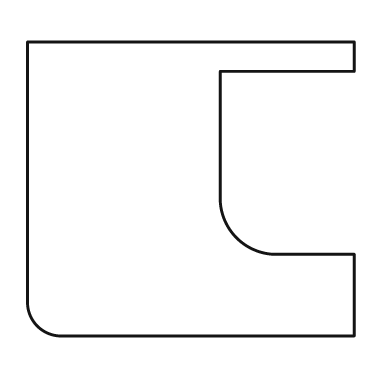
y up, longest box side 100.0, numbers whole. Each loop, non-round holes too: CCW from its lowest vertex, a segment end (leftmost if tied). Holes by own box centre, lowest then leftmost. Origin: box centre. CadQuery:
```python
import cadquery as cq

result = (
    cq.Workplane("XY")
    .moveTo(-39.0, -45.0)
    .lineTo(50.0, -45.0)
    .lineTo(50.0, -20.0)
    .lineTo(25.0, -20.0)
    .threePointArc((14.0, -15.0), (9.0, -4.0))
    .lineTo(9.0, 36.0)
    .lineTo(50.0, 36.0)
    .lineTo(50.0, 45.0)
    .lineTo(-50.0, 45.0)
    .lineTo(-50.0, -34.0)
    .threePointArc((-47.0, -42.0), (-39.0, -45.0))
    .close()
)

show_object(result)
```